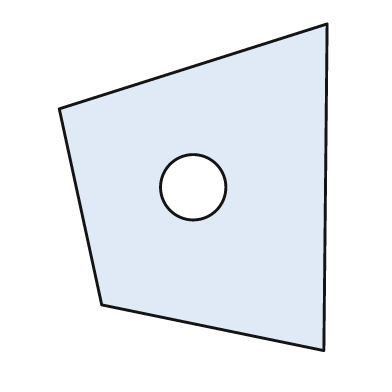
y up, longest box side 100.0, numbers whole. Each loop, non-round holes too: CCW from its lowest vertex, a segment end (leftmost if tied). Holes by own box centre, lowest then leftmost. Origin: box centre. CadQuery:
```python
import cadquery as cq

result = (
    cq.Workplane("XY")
    .moveTo(40.0, -50.0)
    .lineTo(41.0, 50.0)
    .lineTo(-41.0, 24.0)
    .lineTo(-28.0, -36.0)
    .close()
    .moveTo(0.0, 0.0)
    .circle(10.0)
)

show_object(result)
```